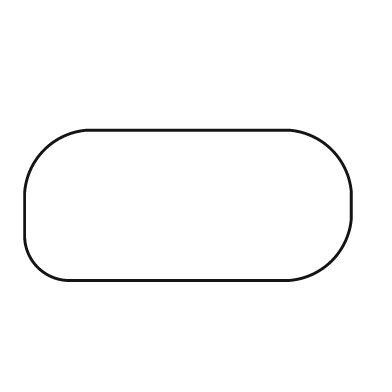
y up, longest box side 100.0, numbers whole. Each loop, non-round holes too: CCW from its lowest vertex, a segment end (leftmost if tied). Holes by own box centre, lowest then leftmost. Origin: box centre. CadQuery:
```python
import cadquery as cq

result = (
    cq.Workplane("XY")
    .moveTo(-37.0, -23.0)
    .lineTo(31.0, -23.0)
    .threePointArc((44.0, -17.0), (50.0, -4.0))
    .lineTo(50.0, 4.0)
    .threePointArc((44.0, 17.0), (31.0, 23.0))
    .lineTo(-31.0, 23.0)
    .threePointArc((-44.0, 17.0), (-50.0, 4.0))
    .lineTo(-50.0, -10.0)
    .threePointArc((-46.0, -19.0), (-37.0, -23.0))
    .close()
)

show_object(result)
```